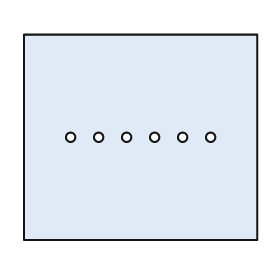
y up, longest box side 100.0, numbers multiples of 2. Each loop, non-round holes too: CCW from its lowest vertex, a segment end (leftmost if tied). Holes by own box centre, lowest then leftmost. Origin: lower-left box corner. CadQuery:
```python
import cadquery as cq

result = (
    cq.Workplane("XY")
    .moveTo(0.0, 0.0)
    .lineTo(100.0, 0.0)
    .lineTo(100.0, 88.0)
    .lineTo(0.0, 88.0)
    .close()
    .moveTo(20.0, 44.0)
    .circle(2.0)
    .moveTo(32.0, 44.0)
    .circle(2.0)
    .moveTo(44.0, 44.0)
    .circle(2.0)
    .moveTo(56.0, 44.0)
    .circle(2.0)
    .moveTo(68.0, 44.0)
    .circle(2.0)
    .moveTo(80.0, 44.0)
    .circle(2.0)
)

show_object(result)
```